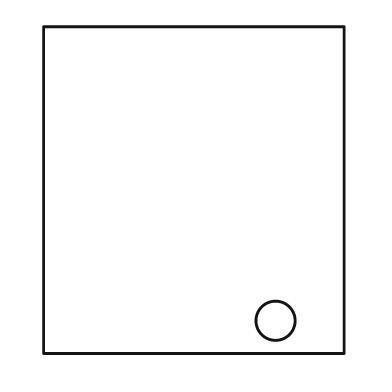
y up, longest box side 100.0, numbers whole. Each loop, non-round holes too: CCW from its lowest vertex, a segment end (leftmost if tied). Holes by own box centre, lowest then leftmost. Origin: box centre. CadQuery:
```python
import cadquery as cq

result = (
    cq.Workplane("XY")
    .moveTo(-46.0, -50.0)
    .lineTo(46.0, -50.0)
    .lineTo(46.0, 50.0)
    .lineTo(-46.0, 50.0)
    .close()
    .moveTo(25.0, -40.0)
    .circle(6.0)
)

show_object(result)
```